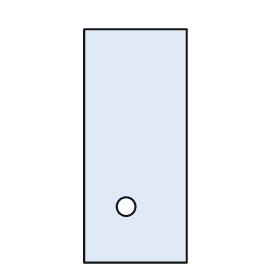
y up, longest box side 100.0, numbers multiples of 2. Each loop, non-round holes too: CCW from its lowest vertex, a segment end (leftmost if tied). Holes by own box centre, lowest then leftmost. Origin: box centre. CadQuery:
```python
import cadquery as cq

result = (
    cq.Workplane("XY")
    .moveTo(-22.0, -50.0)
    .lineTo(22.0, -50.0)
    .lineTo(22.0, 50.0)
    .lineTo(-22.0, 50.0)
    .close()
    .moveTo(-4.0, -26.0)
    .circle(4.0)
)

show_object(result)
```